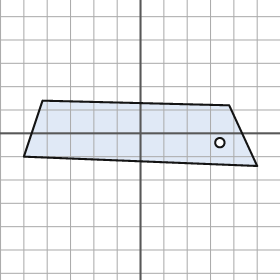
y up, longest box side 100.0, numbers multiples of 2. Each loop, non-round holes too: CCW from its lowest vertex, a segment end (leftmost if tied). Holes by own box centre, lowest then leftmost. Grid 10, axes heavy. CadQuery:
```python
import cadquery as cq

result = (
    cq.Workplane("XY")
    .moveTo(50.0, -14.0)
    .lineTo(38.0, 12.0)
    .lineTo(-42.0, 14.0)
    .lineTo(-50.0, -10.0)
    .close()
    .moveTo(34.0, -4.0)
    .circle(2.0)
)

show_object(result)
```